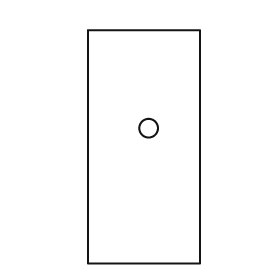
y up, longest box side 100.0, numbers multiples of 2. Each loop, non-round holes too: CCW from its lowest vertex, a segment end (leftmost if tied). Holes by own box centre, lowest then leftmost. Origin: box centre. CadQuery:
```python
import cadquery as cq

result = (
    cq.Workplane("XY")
    .moveTo(-24.0, -50.0)
    .lineTo(24.0, -50.0)
    .lineTo(24.0, 50.0)
    .lineTo(-24.0, 50.0)
    .close()
    .moveTo(2.0, 8.0)
    .circle(4.0)
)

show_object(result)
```